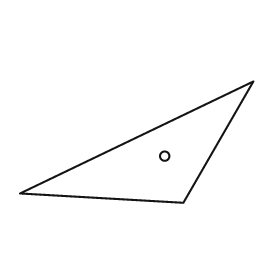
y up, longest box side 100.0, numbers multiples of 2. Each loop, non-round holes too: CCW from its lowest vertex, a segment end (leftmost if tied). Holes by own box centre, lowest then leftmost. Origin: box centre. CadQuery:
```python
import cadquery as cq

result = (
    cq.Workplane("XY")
    .moveTo(20.0, -26.0)
    .lineTo(50.0, 26.0)
    .lineTo(-50.0, -22.0)
    .close()
    .moveTo(12.0, -6.0)
    .circle(2.0)
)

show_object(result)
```